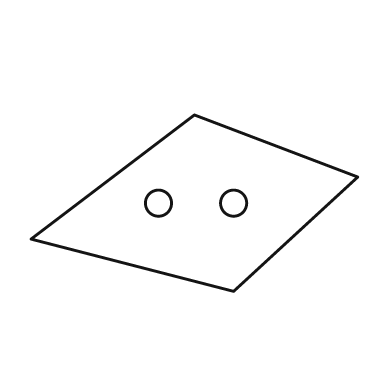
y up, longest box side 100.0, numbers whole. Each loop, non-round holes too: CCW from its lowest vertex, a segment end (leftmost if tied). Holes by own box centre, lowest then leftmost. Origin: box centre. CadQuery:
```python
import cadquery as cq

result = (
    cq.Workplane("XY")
    .moveTo(12.0, -27.0)
    .lineTo(50.0, 8.0)
    .lineTo(0.0, 27.0)
    .lineTo(-50.0, -11.0)
    .close()
    .moveTo(-11.0, 0.0)
    .circle(4.0)
    .moveTo(12.0, 0.0)
    .circle(4.0)
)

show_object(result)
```